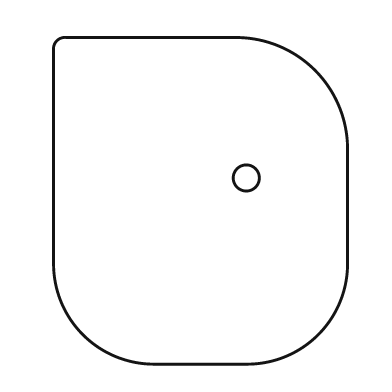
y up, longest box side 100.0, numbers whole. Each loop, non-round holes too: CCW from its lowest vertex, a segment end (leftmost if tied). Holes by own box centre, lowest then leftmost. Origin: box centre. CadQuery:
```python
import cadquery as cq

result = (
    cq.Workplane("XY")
    .moveTo(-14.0, -50.0)
    .lineTo(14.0, -50.0)
    .threePointArc((36.0, -41.0), (45.0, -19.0))
    .lineTo(45.0, 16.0)
    .threePointArc((35.0, 40.0), (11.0, 50.0))
    .lineTo(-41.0, 50.0)
    .threePointArc((-44.0, 49.0), (-45.0, 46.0))
    .lineTo(-45.0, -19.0)
    .threePointArc((-36.0, -41.0), (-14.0, -50.0))
    .close()
    .moveTo(14.0, 7.0)
    .circle(4.0)
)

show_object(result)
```